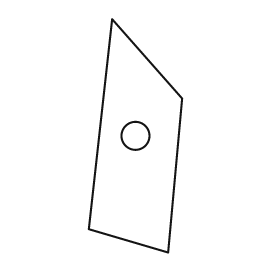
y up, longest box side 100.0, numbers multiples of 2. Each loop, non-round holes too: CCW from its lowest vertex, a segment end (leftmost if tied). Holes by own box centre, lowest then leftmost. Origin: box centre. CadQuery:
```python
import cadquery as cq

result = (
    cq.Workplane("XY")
    .moveTo(14.0, -50.0)
    .lineTo(20.0, 16.0)
    .lineTo(-10.0, 50.0)
    .lineTo(-20.0, -40.0)
    .close()
    .moveTo(0.0, 0.0)
    .circle(6.0)
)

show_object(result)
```